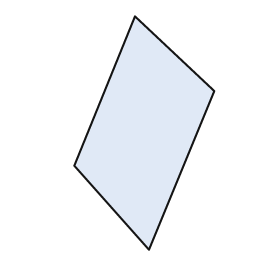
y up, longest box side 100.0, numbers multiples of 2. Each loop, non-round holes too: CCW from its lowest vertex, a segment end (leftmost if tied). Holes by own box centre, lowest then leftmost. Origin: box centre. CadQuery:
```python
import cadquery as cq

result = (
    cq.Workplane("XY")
    .moveTo(2.0, -50.0)
    .lineTo(30.0, 18.0)
    .lineTo(-4.0, 50.0)
    .lineTo(-30.0, -14.0)
    .close()
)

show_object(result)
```